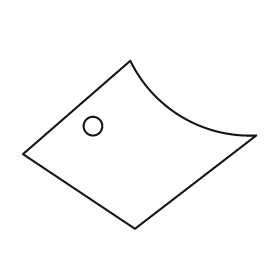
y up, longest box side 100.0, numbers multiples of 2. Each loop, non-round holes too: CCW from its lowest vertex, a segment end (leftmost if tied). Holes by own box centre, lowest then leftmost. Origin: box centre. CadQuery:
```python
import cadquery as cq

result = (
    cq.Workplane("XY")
    .moveTo(-2.0, -36.0)
    .lineTo(50.0, 4.0)
    .threePointArc((18.0, 12.0), (-4.0, 36.0))
    .lineTo(-50.0, -4.0)
    .close()
    .moveTo(-20.0, 8.0)
    .circle(4.0)
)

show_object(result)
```